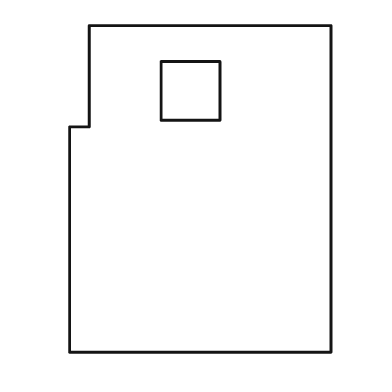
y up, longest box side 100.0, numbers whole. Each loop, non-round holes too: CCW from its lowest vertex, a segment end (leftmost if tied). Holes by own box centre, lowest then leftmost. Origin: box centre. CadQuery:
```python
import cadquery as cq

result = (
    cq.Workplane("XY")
    .moveTo(-40.0, -50.0)
    .lineTo(40.0, -50.0)
    .lineTo(40.0, 50.0)
    .lineTo(-34.0, 50.0)
    .lineTo(-34.0, 19.0)
    .lineTo(-40.0, 19.0)
    .close()
    .moveTo(-12.0, 21.0)
    .lineTo(6.0, 21.0)
    .lineTo(6.0, 39.0)
    .lineTo(-12.0, 39.0)
    .close()
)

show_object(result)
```